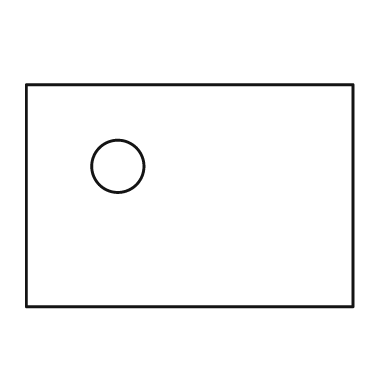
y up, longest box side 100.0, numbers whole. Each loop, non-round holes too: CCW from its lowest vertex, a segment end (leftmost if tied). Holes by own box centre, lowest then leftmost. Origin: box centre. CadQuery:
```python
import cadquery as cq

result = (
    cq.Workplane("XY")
    .moveTo(-50.0, -34.0)
    .lineTo(50.0, -34.0)
    .lineTo(50.0, 34.0)
    .lineTo(-50.0, 34.0)
    .close()
    .moveTo(-22.0, 9.0)
    .circle(8.0)
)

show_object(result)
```